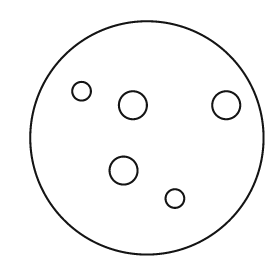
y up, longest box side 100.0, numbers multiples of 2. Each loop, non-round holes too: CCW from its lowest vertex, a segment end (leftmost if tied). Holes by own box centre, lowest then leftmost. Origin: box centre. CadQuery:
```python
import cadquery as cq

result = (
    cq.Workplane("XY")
    .moveTo(0.0, 0.0)
    .circle(50.0)
    .moveTo(12.0, -26.0)
    .circle(4.0)
    .moveTo(-10.0, -14.0)
    .circle(6.0)
    .moveTo(-6.0, 14.0)
    .circle(6.0)
    .moveTo(34.0, 14.0)
    .circle(6.0)
    .moveTo(-28.0, 20.0)
    .circle(4.0)
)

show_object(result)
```